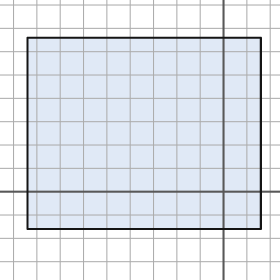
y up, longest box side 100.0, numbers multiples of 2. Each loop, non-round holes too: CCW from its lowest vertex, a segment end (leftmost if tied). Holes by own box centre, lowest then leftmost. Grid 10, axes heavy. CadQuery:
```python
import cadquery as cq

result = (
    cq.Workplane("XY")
    .moveTo(-84.0, -16.0)
    .lineTo(16.0, -16.0)
    .lineTo(16.0, 66.0)
    .lineTo(-84.0, 66.0)
    .close()
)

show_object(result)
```